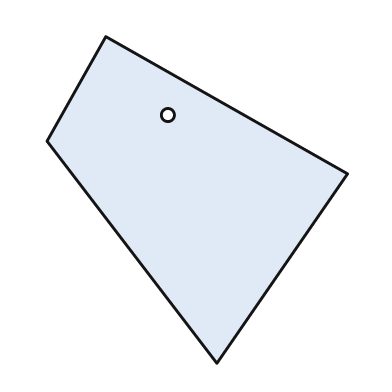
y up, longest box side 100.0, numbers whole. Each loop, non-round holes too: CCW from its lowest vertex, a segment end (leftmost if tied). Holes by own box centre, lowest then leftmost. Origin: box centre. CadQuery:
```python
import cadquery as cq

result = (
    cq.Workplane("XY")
    .moveTo(6.0, -50.0)
    .lineTo(46.0, 8.0)
    .lineTo(-28.0, 50.0)
    .lineTo(-46.0, 18.0)
    .close()
    .moveTo(-9.0, 26.0)
    .circle(2.0)
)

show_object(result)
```